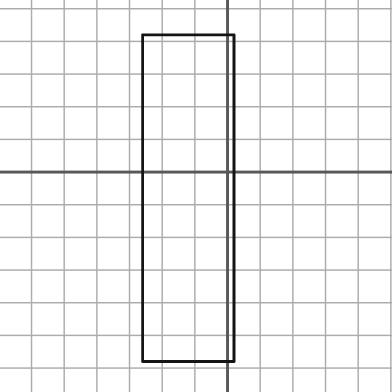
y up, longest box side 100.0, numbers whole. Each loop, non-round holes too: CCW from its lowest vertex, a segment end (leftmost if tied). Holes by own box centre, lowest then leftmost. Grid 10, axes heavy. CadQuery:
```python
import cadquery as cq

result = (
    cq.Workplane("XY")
    .moveTo(-26.0, -58.0)
    .lineTo(2.0, -58.0)
    .lineTo(2.0, 42.0)
    .lineTo(-26.0, 42.0)
    .close()
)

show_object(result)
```